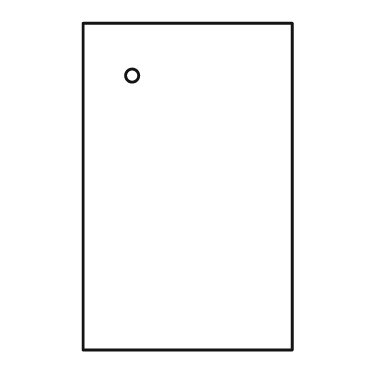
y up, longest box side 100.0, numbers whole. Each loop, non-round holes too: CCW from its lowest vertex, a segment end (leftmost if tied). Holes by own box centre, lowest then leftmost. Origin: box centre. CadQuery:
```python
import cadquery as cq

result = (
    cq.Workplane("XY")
    .moveTo(-32.0, -50.0)
    .lineTo(32.0, -50.0)
    .lineTo(32.0, 50.0)
    .lineTo(-32.0, 50.0)
    .close()
    .moveTo(-17.0, 34.0)
    .circle(2.0)
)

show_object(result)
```